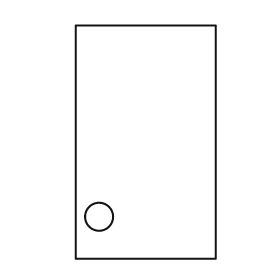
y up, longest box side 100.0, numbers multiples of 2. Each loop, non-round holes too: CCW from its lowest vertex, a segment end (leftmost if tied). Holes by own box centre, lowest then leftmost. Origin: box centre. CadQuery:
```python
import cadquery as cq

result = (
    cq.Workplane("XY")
    .moveTo(-30.0, -50.0)
    .lineTo(30.0, -50.0)
    .lineTo(30.0, 50.0)
    .lineTo(-30.0, 50.0)
    .close()
    .moveTo(-20.0, -32.0)
    .circle(6.0)
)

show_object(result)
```